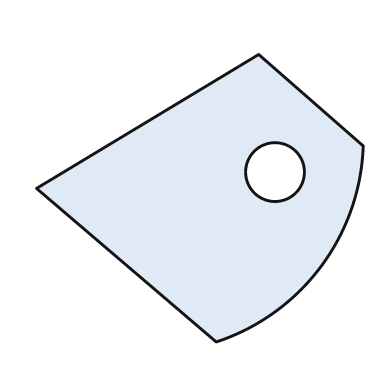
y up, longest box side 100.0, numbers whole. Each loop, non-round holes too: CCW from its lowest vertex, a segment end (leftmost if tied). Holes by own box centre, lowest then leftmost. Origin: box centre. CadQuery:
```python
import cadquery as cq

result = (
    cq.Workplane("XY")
    .moveTo(5.0, -44.0)
    .threePointArc((37.0, -21.0), (50.0, 16.0))
    .lineTo(18.0, 44.0)
    .lineTo(-50.0, 3.0)
    .close()
    .moveTo(23.0, 8.0)
    .circle(9.0)
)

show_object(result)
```